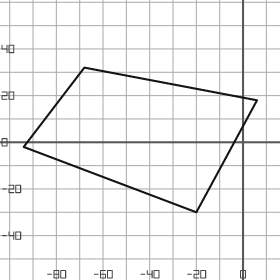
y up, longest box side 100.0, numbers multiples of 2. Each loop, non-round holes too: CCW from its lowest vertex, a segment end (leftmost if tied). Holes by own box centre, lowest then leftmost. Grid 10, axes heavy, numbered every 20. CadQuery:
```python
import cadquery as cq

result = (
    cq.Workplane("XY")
    .moveTo(-20.0, -30.0)
    .lineTo(6.0, 18.0)
    .lineTo(-68.0, 32.0)
    .lineTo(-94.0, -2.0)
    .close()
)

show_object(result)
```